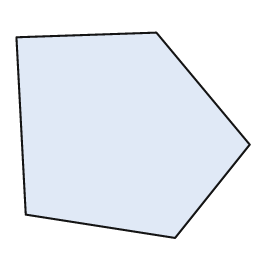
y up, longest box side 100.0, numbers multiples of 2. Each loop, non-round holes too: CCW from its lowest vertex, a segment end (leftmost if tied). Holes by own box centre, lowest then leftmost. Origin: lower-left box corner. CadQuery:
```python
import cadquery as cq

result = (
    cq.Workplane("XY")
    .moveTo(68.0, 0.0)
    .lineTo(100.0, 40.0)
    .lineTo(60.0, 88.0)
    .lineTo(0.0, 86.0)
    .lineTo(4.0, 10.0)
    .close()
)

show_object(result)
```